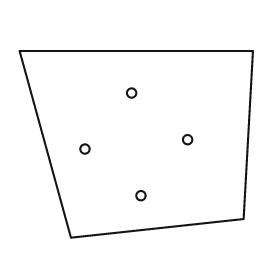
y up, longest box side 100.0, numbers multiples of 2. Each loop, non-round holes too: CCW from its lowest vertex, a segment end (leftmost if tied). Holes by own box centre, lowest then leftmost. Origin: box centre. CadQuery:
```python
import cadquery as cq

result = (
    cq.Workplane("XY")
    .moveTo(-28.0, -40.0)
    .lineTo(46.0, -32.0)
    .lineTo(50.0, 40.0)
    .lineTo(-50.0, 40.0)
    .close()
    .moveTo(2.0, -22.0)
    .circle(2.0)
    .moveTo(-22.0, -2.0)
    .circle(2.0)
    .moveTo(22.0, 2.0)
    .circle(2.0)
    .moveTo(-2.0, 22.0)
    .circle(2.0)
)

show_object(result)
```